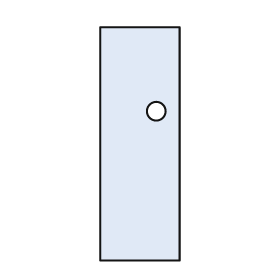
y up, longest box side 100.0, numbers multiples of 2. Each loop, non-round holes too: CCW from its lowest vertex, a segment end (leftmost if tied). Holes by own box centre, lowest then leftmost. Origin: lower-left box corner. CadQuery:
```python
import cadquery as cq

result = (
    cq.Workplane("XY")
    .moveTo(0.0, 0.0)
    .lineTo(34.0, 0.0)
    .lineTo(34.0, 100.0)
    .lineTo(0.0, 100.0)
    .close()
    .moveTo(24.0, 64.0)
    .circle(4.0)
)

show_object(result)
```